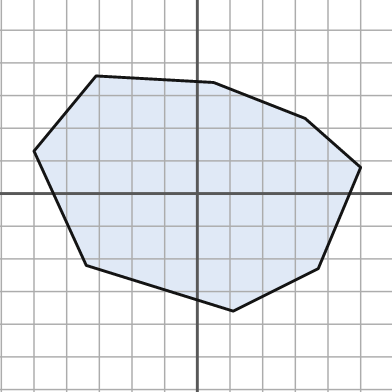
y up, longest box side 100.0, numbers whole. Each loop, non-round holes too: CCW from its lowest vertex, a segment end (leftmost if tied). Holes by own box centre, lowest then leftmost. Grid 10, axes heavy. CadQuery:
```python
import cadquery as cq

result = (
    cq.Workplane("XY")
    .moveTo(11.0, -36.0)
    .lineTo(37.0, -23.0)
    .lineTo(50.0, 8.0)
    .lineTo(33.0, 23.0)
    .lineTo(5.0, 34.0)
    .lineTo(-31.0, 36.0)
    .lineTo(-50.0, 13.0)
    .lineTo(-34.0, -22.0)
    .close()
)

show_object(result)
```